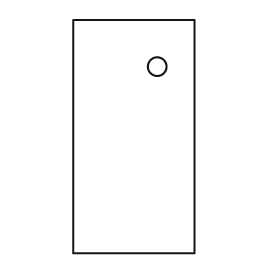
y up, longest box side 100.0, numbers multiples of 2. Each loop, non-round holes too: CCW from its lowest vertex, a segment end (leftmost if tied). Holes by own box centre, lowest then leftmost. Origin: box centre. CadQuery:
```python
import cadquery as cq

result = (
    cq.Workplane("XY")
    .moveTo(-26.0, -50.0)
    .lineTo(26.0, -50.0)
    .lineTo(26.0, 50.0)
    .lineTo(-26.0, 50.0)
    .close()
    .moveTo(10.0, 30.0)
    .circle(4.0)
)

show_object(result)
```